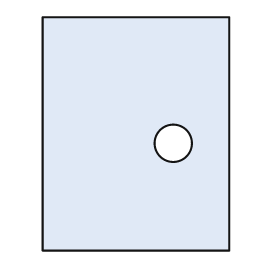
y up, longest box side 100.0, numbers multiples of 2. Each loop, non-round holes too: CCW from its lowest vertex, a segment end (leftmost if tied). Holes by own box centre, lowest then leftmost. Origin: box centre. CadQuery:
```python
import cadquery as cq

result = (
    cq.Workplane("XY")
    .moveTo(-40.0, -50.0)
    .lineTo(40.0, -50.0)
    .lineTo(40.0, 50.0)
    .lineTo(-40.0, 50.0)
    .close()
    .moveTo(16.0, -4.0)
    .circle(8.0)
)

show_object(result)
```